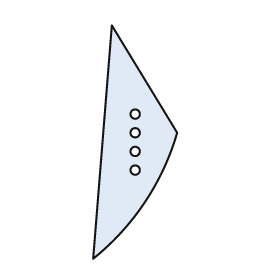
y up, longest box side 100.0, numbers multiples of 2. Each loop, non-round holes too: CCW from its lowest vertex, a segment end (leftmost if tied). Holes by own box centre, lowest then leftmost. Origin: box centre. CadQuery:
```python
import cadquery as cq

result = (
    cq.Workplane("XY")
    .moveTo(-18.0, -50.0)
    .threePointArc((4.0, -26.0), (18.0, 4.0))
    .lineTo(-10.0, 50.0)
    .close()
    .moveTo(0.0, -12.0)
    .circle(2.0)
    .moveTo(0.0, -4.0)
    .circle(2.0)
    .moveTo(0.0, 4.0)
    .circle(2.0)
    .moveTo(0.0, 12.0)
    .circle(2.0)
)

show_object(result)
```